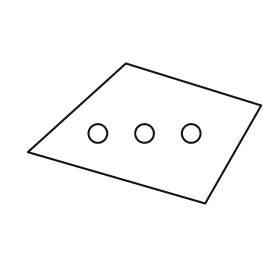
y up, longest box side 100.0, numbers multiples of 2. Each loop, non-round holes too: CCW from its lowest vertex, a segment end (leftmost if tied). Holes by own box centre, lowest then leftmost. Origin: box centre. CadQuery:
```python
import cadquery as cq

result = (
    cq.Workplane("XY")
    .moveTo(26.0, -30.0)
    .lineTo(50.0, 12.0)
    .lineTo(-8.0, 30.0)
    .lineTo(-50.0, -8.0)
    .close()
    .moveTo(-20.0, 0.0)
    .circle(4.0)
    .moveTo(0.0, 0.0)
    .circle(4.0)
    .moveTo(20.0, 0.0)
    .circle(4.0)
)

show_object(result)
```